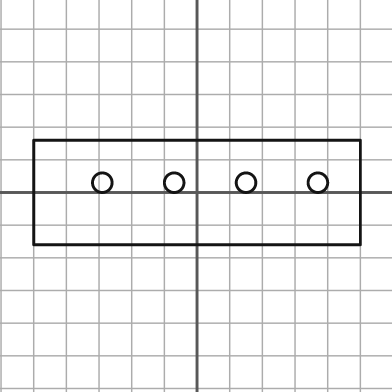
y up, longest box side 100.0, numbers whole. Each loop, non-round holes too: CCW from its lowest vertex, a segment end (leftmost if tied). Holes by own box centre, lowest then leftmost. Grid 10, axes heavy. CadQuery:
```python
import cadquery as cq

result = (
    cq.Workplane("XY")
    .moveTo(-50.0, -16.0)
    .lineTo(50.0, -16.0)
    .lineTo(50.0, 16.0)
    .lineTo(-50.0, 16.0)
    .close()
    .moveTo(-29.0, 3.0)
    .circle(3.0)
    .moveTo(-7.0, 3.0)
    .circle(3.0)
    .moveTo(15.0, 3.0)
    .circle(3.0)
    .moveTo(37.0, 3.0)
    .circle(3.0)
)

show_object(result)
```